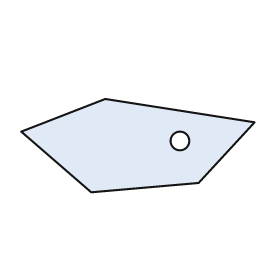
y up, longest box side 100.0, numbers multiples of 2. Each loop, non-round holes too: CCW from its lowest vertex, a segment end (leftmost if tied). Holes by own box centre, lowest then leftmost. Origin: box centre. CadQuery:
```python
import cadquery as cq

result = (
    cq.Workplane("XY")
    .moveTo(-20.0, -20.0)
    .lineTo(26.0, -16.0)
    .lineTo(50.0, 10.0)
    .lineTo(-14.0, 20.0)
    .lineTo(-50.0, 6.0)
    .close()
    .moveTo(18.0, 2.0)
    .circle(4.0)
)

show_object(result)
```